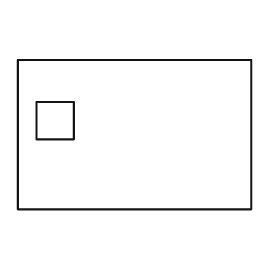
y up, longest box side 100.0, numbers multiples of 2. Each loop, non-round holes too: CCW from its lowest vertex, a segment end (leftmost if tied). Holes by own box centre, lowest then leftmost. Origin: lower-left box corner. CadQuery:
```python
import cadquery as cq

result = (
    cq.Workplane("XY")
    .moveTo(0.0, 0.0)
    .lineTo(100.0, 0.0)
    .lineTo(100.0, 64.0)
    .lineTo(0.0, 64.0)
    .close()
    .moveTo(8.0, 30.0)
    .lineTo(24.0, 30.0)
    .lineTo(24.0, 46.0)
    .lineTo(8.0, 46.0)
    .close()
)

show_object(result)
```